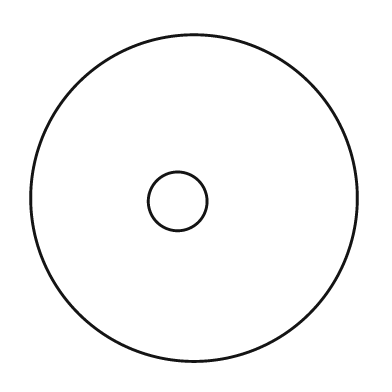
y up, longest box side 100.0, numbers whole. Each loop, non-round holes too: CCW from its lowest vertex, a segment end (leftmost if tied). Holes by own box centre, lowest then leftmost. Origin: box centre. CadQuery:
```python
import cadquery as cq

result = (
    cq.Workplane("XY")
    .moveTo(0.0, 0.0)
    .circle(50.0)
    .moveTo(-5.0, -1.0)
    .circle(9.0)
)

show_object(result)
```